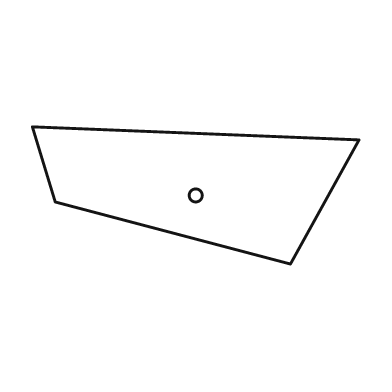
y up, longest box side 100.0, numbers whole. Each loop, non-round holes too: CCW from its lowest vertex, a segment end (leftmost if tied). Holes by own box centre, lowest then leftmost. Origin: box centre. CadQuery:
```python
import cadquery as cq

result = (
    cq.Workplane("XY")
    .moveTo(29.0, -21.0)
    .lineTo(50.0, 17.0)
    .lineTo(-50.0, 21.0)
    .lineTo(-43.0, -2.0)
    .close()
    .moveTo(0.0, 0.0)
    .circle(2.0)
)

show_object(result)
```